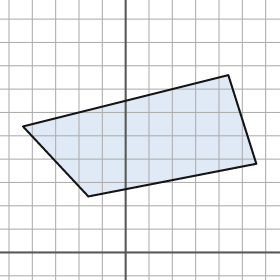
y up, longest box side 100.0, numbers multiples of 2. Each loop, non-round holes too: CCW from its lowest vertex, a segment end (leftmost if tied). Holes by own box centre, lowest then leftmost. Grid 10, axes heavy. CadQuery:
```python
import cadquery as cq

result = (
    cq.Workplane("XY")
    .moveTo(-16.0, 24.0)
    .lineTo(56.0, 38.0)
    .lineTo(44.0, 76.0)
    .lineTo(-44.0, 54.0)
    .close()
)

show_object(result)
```